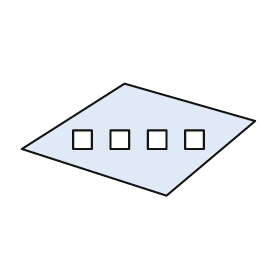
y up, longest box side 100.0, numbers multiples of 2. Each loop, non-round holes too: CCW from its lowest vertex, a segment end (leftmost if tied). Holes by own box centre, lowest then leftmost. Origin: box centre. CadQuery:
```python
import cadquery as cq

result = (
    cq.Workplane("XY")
    .moveTo(12.0, -24.0)
    .lineTo(50.0, 8.0)
    .lineTo(-6.0, 24.0)
    .lineTo(-50.0, -4.0)
    .close()
    .moveTo(-28.0, -4.0)
    .lineTo(-20.0, -4.0)
    .lineTo(-20.0, 4.0)
    .lineTo(-28.0, 4.0)
    .close()
    .moveTo(-12.0, -4.0)
    .lineTo(-4.0, -4.0)
    .lineTo(-4.0, 4.0)
    .lineTo(-12.0, 4.0)
    .close()
    .moveTo(4.0, -4.0)
    .lineTo(12.0, -4.0)
    .lineTo(12.0, 4.0)
    .lineTo(4.0, 4.0)
    .close()
    .moveTo(20.0, -4.0)
    .lineTo(28.0, -4.0)
    .lineTo(28.0, 4.0)
    .lineTo(20.0, 4.0)
    .close()
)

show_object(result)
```